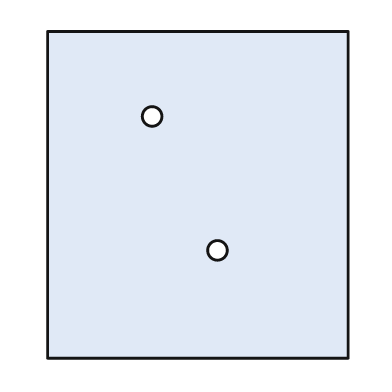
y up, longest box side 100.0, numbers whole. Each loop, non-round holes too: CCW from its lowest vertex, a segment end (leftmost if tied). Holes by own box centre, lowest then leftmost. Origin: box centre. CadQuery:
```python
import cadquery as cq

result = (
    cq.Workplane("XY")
    .moveTo(-46.0, -50.0)
    .lineTo(46.0, -50.0)
    .lineTo(46.0, 50.0)
    .lineTo(-46.0, 50.0)
    .close()
    .moveTo(6.0, -17.0)
    .circle(3.0)
    .moveTo(-14.0, 24.0)
    .circle(3.0)
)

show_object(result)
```